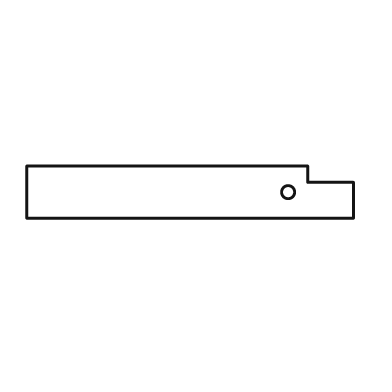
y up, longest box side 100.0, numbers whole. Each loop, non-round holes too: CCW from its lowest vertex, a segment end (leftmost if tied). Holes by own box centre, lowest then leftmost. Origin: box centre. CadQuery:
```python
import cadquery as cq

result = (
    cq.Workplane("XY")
    .moveTo(-50.0, -8.0)
    .lineTo(50.0, -8.0)
    .lineTo(50.0, 3.0)
    .lineTo(36.0, 3.0)
    .lineTo(36.0, 8.0)
    .lineTo(-50.0, 8.0)
    .close()
    .moveTo(30.0, 0.0)
    .circle(2.0)
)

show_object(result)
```